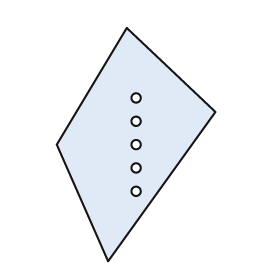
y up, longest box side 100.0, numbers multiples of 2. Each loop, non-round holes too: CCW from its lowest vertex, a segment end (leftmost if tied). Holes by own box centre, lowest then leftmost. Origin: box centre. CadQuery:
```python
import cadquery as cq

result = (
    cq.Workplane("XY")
    .moveTo(-12.0, -50.0)
    .lineTo(34.0, 14.0)
    .lineTo(-4.0, 50.0)
    .lineTo(-34.0, 0.0)
    .close()
    .moveTo(0.0, -20.0)
    .circle(2.0)
    .moveTo(0.0, -10.0)
    .circle(2.0)
    .moveTo(0.0, 0.0)
    .circle(2.0)
    .moveTo(0.0, 10.0)
    .circle(2.0)
    .moveTo(0.0, 20.0)
    .circle(2.0)
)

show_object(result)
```